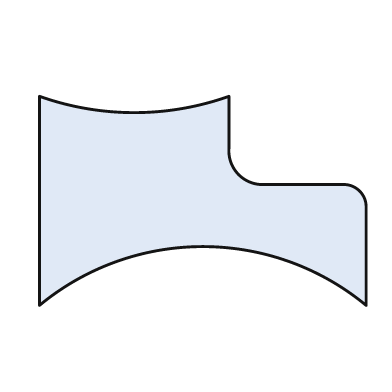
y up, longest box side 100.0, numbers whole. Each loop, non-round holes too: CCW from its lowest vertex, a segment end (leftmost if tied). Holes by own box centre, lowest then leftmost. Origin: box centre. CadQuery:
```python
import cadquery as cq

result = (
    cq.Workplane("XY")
    .moveTo(-50.0, -32.0)
    .threePointArc((0.0, -14.0), (50.0, -32.0))
    .lineTo(50.0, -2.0)
    .threePointArc((48.0, 3.0), (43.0, 5.0))
    .lineTo(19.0, 5.0)
    .threePointArc((11.0, 8.0), (8.0, 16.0))
    .lineTo(8.0, 32.0)
    .threePointArc((-21.0, 27.0), (-50.0, 32.0))
    .close()
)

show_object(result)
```